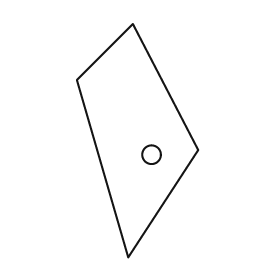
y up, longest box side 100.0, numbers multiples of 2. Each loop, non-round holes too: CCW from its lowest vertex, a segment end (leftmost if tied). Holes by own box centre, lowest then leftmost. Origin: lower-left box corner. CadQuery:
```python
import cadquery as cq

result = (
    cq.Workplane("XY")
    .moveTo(22.0, 0.0)
    .lineTo(52.0, 46.0)
    .lineTo(24.0, 100.0)
    .lineTo(0.0, 76.0)
    .close()
    .moveTo(32.0, 44.0)
    .circle(4.0)
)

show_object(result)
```